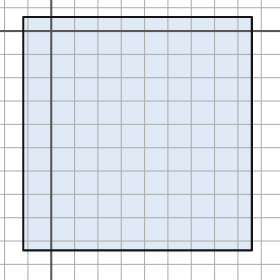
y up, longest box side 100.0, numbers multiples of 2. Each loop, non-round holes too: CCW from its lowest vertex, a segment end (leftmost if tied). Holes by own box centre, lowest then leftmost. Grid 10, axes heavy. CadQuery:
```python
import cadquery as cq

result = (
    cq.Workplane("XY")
    .moveTo(-12.0, -94.0)
    .lineTo(86.0, -94.0)
    .lineTo(86.0, 6.0)
    .lineTo(-12.0, 6.0)
    .close()
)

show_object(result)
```